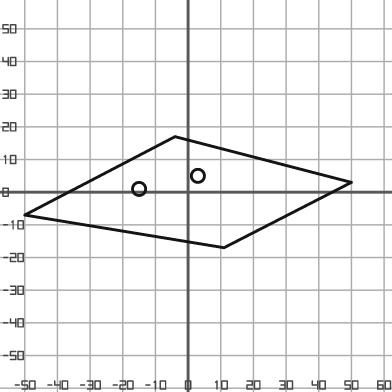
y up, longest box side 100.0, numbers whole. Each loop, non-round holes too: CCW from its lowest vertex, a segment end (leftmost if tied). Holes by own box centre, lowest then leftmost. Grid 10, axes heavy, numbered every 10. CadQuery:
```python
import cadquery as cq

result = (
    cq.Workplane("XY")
    .moveTo(11.0, -17.0)
    .lineTo(50.0, 3.0)
    .lineTo(-4.0, 17.0)
    .lineTo(-50.0, -7.0)
    .close()
    .moveTo(-15.0, 1.0)
    .circle(2.0)
    .moveTo(3.0, 5.0)
    .circle(2.0)
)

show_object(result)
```